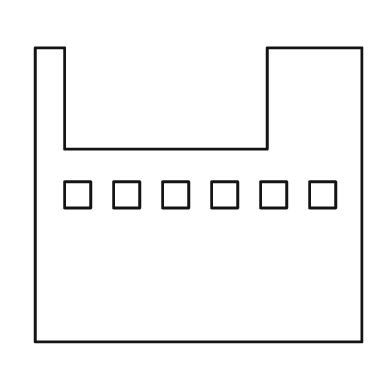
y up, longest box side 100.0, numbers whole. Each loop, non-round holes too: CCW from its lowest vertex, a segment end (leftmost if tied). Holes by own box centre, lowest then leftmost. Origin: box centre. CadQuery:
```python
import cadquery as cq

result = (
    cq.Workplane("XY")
    .moveTo(-50.0, -45.0)
    .lineTo(50.0, -45.0)
    .lineTo(50.0, 45.0)
    .lineTo(21.0, 45.0)
    .lineTo(21.0, 14.0)
    .lineTo(-41.0, 14.0)
    .lineTo(-41.0, 45.0)
    .lineTo(-50.0, 45.0)
    .close()
    .moveTo(-41.0, -4.0)
    .lineTo(-33.0, -4.0)
    .lineTo(-33.0, 4.0)
    .lineTo(-41.0, 4.0)
    .close()
    .moveTo(-26.0, -4.0)
    .lineTo(-18.0, -4.0)
    .lineTo(-18.0, 4.0)
    .lineTo(-26.0, 4.0)
    .close()
    .moveTo(-11.0, -4.0)
    .lineTo(-3.0, -4.0)
    .lineTo(-3.0, 4.0)
    .lineTo(-11.0, 4.0)
    .close()
    .moveTo(4.0, -4.0)
    .lineTo(12.0, -4.0)
    .lineTo(12.0, 4.0)
    .lineTo(4.0, 4.0)
    .close()
    .moveTo(19.0, -4.0)
    .lineTo(27.0, -4.0)
    .lineTo(27.0, 4.0)
    .lineTo(19.0, 4.0)
    .close()
    .moveTo(34.0, -4.0)
    .lineTo(42.0, -4.0)
    .lineTo(42.0, 4.0)
    .lineTo(34.0, 4.0)
    .close()
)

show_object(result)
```